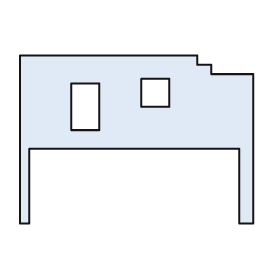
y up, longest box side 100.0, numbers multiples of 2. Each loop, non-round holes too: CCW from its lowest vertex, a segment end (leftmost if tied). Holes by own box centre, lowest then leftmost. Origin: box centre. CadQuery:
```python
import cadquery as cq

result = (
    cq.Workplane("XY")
    .moveTo(-50.0, -36.0)
    .lineTo(-46.0, -36.0)
    .lineTo(-46.0, -4.0)
    .lineTo(44.0, -4.0)
    .lineTo(44.0, -36.0)
    .lineTo(50.0, -36.0)
    .lineTo(50.0, 28.0)
    .lineTo(32.0, 28.0)
    .lineTo(32.0, 32.0)
    .lineTo(26.0, 32.0)
    .lineTo(26.0, 36.0)
    .lineTo(-50.0, 36.0)
    .close()
    .moveTo(-28.0, 4.0)
    .lineTo(-16.0, 4.0)
    .lineTo(-16.0, 24.0)
    .lineTo(-28.0, 24.0)
    .close()
    .moveTo(2.0, 14.0)
    .lineTo(14.0, 14.0)
    .lineTo(14.0, 26.0)
    .lineTo(2.0, 26.0)
    .close()
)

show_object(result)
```